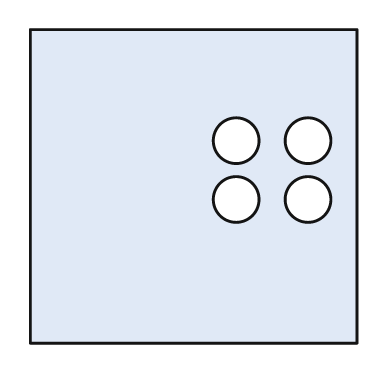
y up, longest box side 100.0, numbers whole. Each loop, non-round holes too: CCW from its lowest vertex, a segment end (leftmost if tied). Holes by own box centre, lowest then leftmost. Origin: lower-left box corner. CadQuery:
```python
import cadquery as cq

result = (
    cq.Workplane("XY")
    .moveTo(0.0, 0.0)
    .lineTo(100.0, 0.0)
    .lineTo(100.0, 96.0)
    .lineTo(0.0, 96.0)
    .close()
    .moveTo(63.0, 44.0)
    .circle(7.0)
    .moveTo(85.0, 44.0)
    .circle(7.0)
    .moveTo(63.0, 62.0)
    .circle(7.0)
    .moveTo(85.0, 62.0)
    .circle(7.0)
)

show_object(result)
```